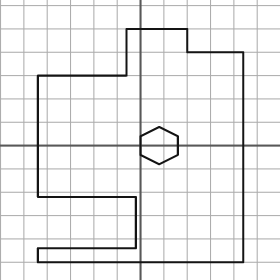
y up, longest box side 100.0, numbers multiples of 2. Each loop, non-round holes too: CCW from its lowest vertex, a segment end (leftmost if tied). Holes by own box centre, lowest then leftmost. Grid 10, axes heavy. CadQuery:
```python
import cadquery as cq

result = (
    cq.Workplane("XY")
    .moveTo(-44.0, -50.0)
    .lineTo(44.0, -50.0)
    .lineTo(44.0, 40.0)
    .lineTo(20.0, 40.0)
    .lineTo(20.0, 50.0)
    .lineTo(-6.0, 50.0)
    .lineTo(-6.0, 30.0)
    .lineTo(-44.0, 30.0)
    .lineTo(-44.0, -22.0)
    .lineTo(-2.0, -22.0)
    .lineTo(-2.0, -44.0)
    .lineTo(-44.0, -44.0)
    .close()
    .moveTo(8.0, -8.0)
    .lineTo(16.0, -4.0)
    .lineTo(16.0, 4.0)
    .lineTo(8.0, 8.0)
    .lineTo(0.0, 4.0)
    .lineTo(0.0, -4.0)
    .close()
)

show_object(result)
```